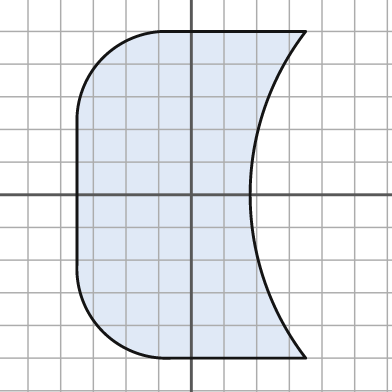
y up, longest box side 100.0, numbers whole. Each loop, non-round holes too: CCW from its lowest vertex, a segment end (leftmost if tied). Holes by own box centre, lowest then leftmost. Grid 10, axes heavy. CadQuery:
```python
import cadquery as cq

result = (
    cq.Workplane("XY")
    .moveTo(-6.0, -50.0)
    .lineTo(35.0, -50.0)
    .threePointArc((18.0, 0.0), (35.0, 50.0))
    .lineTo(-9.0, 50.0)
    .threePointArc((-27.0, 42.0), (-35.0, 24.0))
    .lineTo(-35.0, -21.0)
    .threePointArc((-27.0, -42.0), (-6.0, -50.0))
    .close()
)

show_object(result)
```